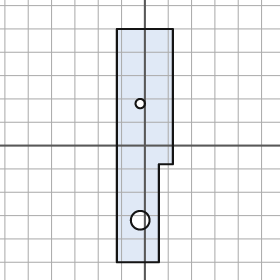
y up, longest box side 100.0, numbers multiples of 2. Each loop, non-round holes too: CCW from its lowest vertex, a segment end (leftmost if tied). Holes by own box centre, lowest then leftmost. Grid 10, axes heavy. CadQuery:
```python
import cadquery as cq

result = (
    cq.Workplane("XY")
    .moveTo(-12.0, -50.0)
    .lineTo(6.0, -50.0)
    .lineTo(6.0, -8.0)
    .lineTo(12.0, -8.0)
    .lineTo(12.0, 50.0)
    .lineTo(-12.0, 50.0)
    .close()
    .moveTo(-2.0, -32.0)
    .circle(4.0)
    .moveTo(-2.0, 18.0)
    .circle(2.0)
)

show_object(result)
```